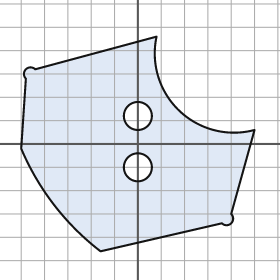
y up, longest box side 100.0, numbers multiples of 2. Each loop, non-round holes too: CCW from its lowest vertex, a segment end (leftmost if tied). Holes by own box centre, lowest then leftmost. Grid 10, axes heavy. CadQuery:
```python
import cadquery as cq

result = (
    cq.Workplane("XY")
    .moveTo(-16.0, -46.0)
    .lineTo(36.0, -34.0)
    .threePointArc((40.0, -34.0), (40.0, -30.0))
    .lineTo(50.0, 6.0)
    .threePointArc((18.0, 14.0), (8.0, 46.0))
    .lineTo(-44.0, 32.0)
    .threePointArc((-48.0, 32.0), (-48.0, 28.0))
    .lineTo(-50.0, -2.0)
    .threePointArc((-36.0, -26.0), (-16.0, -46.0))
    .close()
    .moveTo(0.0, -10.0)
    .circle(6.0)
    .moveTo(0.0, 12.0)
    .circle(6.0)
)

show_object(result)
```